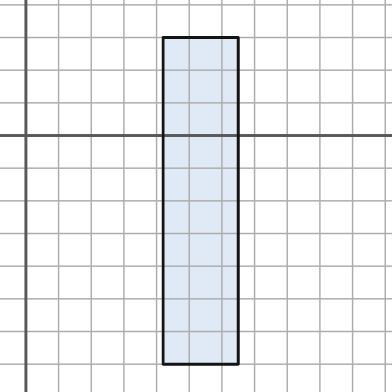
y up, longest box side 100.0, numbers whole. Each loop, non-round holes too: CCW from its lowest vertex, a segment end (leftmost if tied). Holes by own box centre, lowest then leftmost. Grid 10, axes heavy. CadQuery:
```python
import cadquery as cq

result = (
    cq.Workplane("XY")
    .moveTo(42.0, -70.0)
    .lineTo(65.0, -70.0)
    .lineTo(65.0, 30.0)
    .lineTo(42.0, 30.0)
    .close()
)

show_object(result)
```